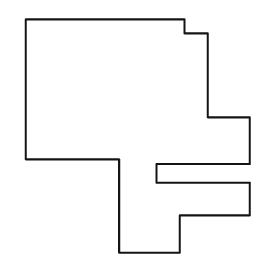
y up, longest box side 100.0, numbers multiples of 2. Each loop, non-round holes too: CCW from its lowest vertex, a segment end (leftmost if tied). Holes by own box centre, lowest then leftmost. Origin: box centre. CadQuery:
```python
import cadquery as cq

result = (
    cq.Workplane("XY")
    .moveTo(-8.0, -50.0)
    .lineTo(18.0, -50.0)
    .lineTo(18.0, -34.0)
    .lineTo(48.0, -34.0)
    .lineTo(48.0, -20.0)
    .lineTo(8.0, -20.0)
    .lineTo(8.0, -12.0)
    .lineTo(48.0, -12.0)
    .lineTo(48.0, 8.0)
    .lineTo(30.0, 8.0)
    .lineTo(30.0, 44.0)
    .lineTo(20.0, 44.0)
    .lineTo(20.0, 50.0)
    .lineTo(-48.0, 50.0)
    .lineTo(-48.0, -10.0)
    .lineTo(-8.0, -10.0)
    .close()
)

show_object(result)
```